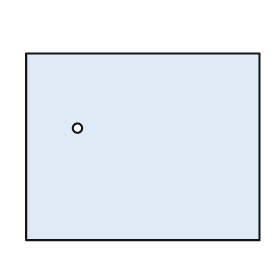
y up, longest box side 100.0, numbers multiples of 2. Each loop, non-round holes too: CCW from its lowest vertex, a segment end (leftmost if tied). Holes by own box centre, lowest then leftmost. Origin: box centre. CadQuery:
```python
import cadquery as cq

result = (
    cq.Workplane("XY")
    .moveTo(-50.0, -40.0)
    .lineTo(50.0, -40.0)
    .lineTo(50.0, 40.0)
    .lineTo(-50.0, 40.0)
    .close()
    .moveTo(-28.0, 8.0)
    .circle(2.0)
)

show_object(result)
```